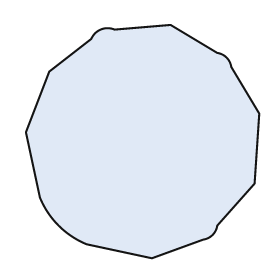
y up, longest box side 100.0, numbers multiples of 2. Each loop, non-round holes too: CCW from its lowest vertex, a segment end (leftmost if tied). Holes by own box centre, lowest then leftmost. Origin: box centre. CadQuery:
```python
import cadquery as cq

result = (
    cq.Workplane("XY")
    .moveTo(4.0, -50.0)
    .lineTo(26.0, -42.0)
    .threePointArc((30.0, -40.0), (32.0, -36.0))
    .lineTo(48.0, -18.0)
    .lineTo(50.0, 12.0)
    .lineTo(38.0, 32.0)
    .threePointArc((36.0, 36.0), (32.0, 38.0))
    .lineTo(12.0, 50.0)
    .lineTo(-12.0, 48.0)
    .threePointArc((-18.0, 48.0), (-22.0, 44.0))
    .lineTo(-40.0, 30.0)
    .lineTo(-50.0, 4.0)
    .lineTo(-44.0, -24.0)
    .threePointArc((-36.0, -36.0), (-24.0, -44.0))
    .close()
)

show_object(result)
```